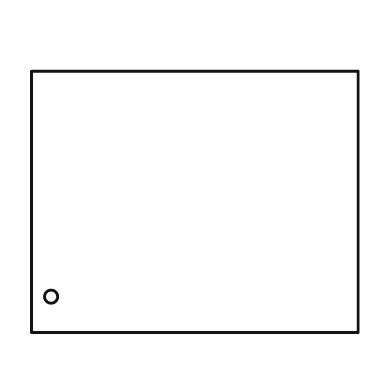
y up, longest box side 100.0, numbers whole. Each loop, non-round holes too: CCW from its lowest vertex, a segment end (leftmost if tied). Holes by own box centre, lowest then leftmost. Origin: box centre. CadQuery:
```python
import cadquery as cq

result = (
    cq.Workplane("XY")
    .moveTo(-50.0, -40.0)
    .lineTo(50.0, -40.0)
    .lineTo(50.0, 40.0)
    .lineTo(-50.0, 40.0)
    .close()
    .moveTo(-44.0, -29.0)
    .circle(2.0)
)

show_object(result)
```